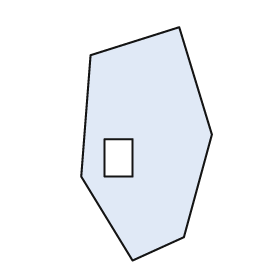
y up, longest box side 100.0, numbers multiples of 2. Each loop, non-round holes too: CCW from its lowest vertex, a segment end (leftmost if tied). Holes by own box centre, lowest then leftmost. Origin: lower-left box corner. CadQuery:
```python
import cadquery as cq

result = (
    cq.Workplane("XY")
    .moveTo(22.0, 0.0)
    .lineTo(44.0, 10.0)
    .lineTo(56.0, 54.0)
    .lineTo(42.0, 100.0)
    .lineTo(4.0, 88.0)
    .lineTo(0.0, 36.0)
    .close()
    .moveTo(10.0, 36.0)
    .lineTo(22.0, 36.0)
    .lineTo(22.0, 52.0)
    .lineTo(10.0, 52.0)
    .close()
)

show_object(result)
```